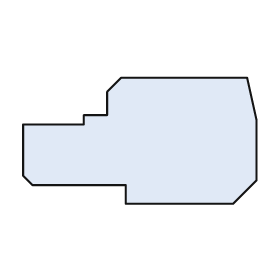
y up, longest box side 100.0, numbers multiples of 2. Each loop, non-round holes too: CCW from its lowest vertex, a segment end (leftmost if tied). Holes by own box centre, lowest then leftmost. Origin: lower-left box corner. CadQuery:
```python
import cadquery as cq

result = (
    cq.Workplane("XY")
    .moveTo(44.0, 0.0)
    .lineTo(90.0, 0.0)
    .lineTo(100.0, 10.0)
    .lineTo(100.0, 36.0)
    .lineTo(96.0, 54.0)
    .lineTo(42.0, 54.0)
    .lineTo(36.0, 48.0)
    .lineTo(36.0, 38.0)
    .lineTo(26.0, 38.0)
    .lineTo(26.0, 34.0)
    .lineTo(0.0, 34.0)
    .lineTo(0.0, 12.0)
    .lineTo(4.0, 8.0)
    .lineTo(44.0, 8.0)
    .close()
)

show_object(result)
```